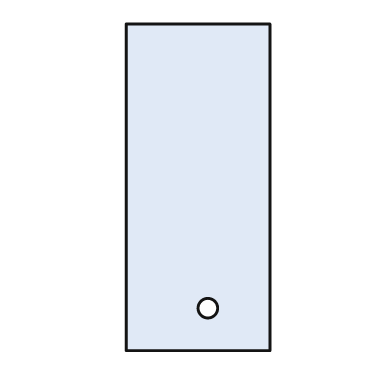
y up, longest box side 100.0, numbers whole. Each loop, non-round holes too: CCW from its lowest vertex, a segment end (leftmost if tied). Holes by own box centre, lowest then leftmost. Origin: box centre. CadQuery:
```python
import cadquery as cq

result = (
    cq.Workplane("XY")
    .moveTo(-22.0, -50.0)
    .lineTo(22.0, -50.0)
    .lineTo(22.0, 50.0)
    .lineTo(-22.0, 50.0)
    .close()
    .moveTo(3.0, -37.0)
    .circle(3.0)
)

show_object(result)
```